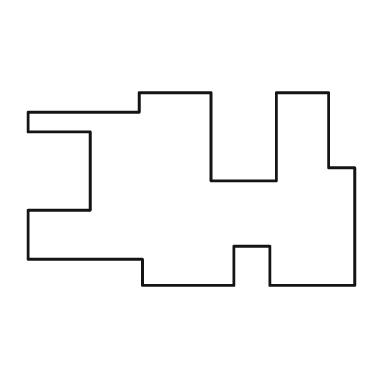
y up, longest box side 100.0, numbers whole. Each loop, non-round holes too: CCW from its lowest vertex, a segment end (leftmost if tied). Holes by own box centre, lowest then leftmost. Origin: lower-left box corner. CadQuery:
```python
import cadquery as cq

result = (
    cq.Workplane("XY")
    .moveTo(35.0, 0.0)
    .lineTo(63.0, 0.0)
    .lineTo(63.0, 12.0)
    .lineTo(74.0, 12.0)
    .lineTo(74.0, 0.0)
    .lineTo(100.0, 0.0)
    .lineTo(100.0, 36.0)
    .lineTo(92.0, 36.0)
    .lineTo(92.0, 59.0)
    .lineTo(76.0, 59.0)
    .lineTo(76.0, 32.0)
    .lineTo(56.0, 32.0)
    .lineTo(56.0, 59.0)
    .lineTo(34.0, 59.0)
    .lineTo(34.0, 53.0)
    .lineTo(0.0, 53.0)
    .lineTo(0.0, 47.0)
    .lineTo(19.0, 47.0)
    .lineTo(19.0, 23.0)
    .lineTo(0.0, 23.0)
    .lineTo(0.0, 8.0)
    .lineTo(35.0, 8.0)
    .close()
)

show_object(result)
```